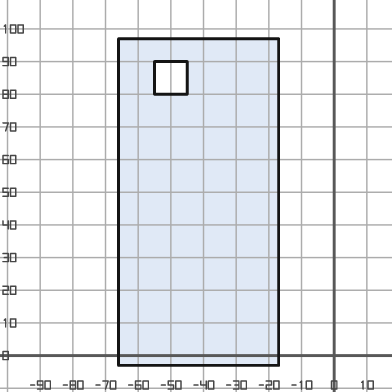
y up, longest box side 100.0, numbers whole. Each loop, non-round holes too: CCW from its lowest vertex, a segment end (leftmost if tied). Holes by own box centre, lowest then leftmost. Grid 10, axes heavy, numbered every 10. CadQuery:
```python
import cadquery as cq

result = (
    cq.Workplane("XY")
    .moveTo(-66.0, -3.0)
    .lineTo(-17.0, -3.0)
    .lineTo(-17.0, 97.0)
    .lineTo(-66.0, 97.0)
    .close()
    .moveTo(-55.0, 80.0)
    .lineTo(-45.0, 80.0)
    .lineTo(-45.0, 90.0)
    .lineTo(-55.0, 90.0)
    .close()
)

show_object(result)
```